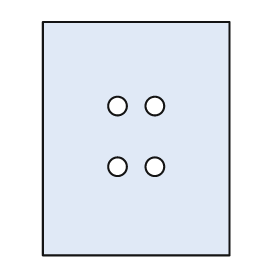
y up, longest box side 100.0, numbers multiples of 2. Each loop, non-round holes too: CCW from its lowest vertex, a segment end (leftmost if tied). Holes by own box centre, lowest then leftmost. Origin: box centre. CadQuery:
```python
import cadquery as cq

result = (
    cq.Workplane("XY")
    .moveTo(-40.0, -50.0)
    .lineTo(40.0, -50.0)
    .lineTo(40.0, 50.0)
    .lineTo(-40.0, 50.0)
    .close()
    .moveTo(-8.0, -12.0)
    .circle(4.0)
    .moveTo(8.0, -12.0)
    .circle(4.0)
    .moveTo(-8.0, 14.0)
    .circle(4.0)
    .moveTo(8.0, 14.0)
    .circle(4.0)
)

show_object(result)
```